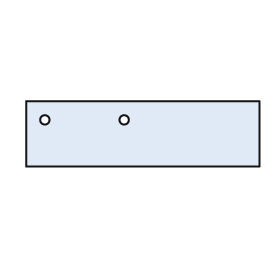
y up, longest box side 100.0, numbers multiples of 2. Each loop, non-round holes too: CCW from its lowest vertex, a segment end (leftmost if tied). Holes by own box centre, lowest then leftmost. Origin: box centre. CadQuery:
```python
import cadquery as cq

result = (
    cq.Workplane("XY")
    .moveTo(-50.0, -14.0)
    .lineTo(50.0, -14.0)
    .lineTo(50.0, 14.0)
    .lineTo(-50.0, 14.0)
    .close()
    .moveTo(-42.0, 6.0)
    .circle(2.0)
    .moveTo(-8.0, 6.0)
    .circle(2.0)
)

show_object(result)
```